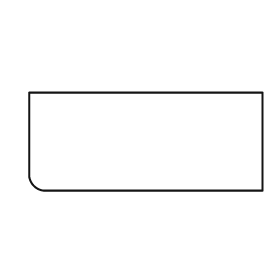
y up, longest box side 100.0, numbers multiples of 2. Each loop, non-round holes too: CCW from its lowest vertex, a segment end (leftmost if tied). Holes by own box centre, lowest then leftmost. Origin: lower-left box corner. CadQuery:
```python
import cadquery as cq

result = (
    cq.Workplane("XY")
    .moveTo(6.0, 0.0)
    .lineTo(100.0, 0.0)
    .lineTo(100.0, 42.0)
    .lineTo(0.0, 42.0)
    .lineTo(0.0, 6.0)
    .threePointArc((2.0, 2.0), (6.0, 0.0))
    .close()
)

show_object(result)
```